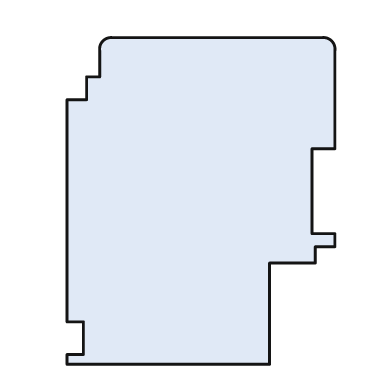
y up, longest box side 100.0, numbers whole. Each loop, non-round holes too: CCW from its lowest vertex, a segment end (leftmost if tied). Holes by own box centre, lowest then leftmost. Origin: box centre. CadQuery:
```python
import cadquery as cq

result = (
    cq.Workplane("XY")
    .moveTo(-41.0, -50.0)
    .lineTo(21.0, -50.0)
    .lineTo(21.0, -19.0)
    .lineTo(35.0, -19.0)
    .lineTo(35.0, -14.0)
    .lineTo(41.0, -14.0)
    .lineTo(41.0, -10.0)
    .lineTo(34.0, -10.0)
    .lineTo(34.0, 16.0)
    .lineTo(41.0, 16.0)
    .lineTo(41.0, 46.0)
    .threePointArc((40.0, 49.0), (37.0, 50.0))
    .lineTo(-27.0, 50.0)
    .threePointArc((-30.0, 49.0), (-31.0, 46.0))
    .lineTo(-31.0, 38.0)
    .lineTo(-35.0, 38.0)
    .lineTo(-35.0, 31.0)
    .lineTo(-41.0, 31.0)
    .lineTo(-41.0, -37.0)
    .lineTo(-36.0, -37.0)
    .lineTo(-36.0, -47.0)
    .lineTo(-41.0, -47.0)
    .close()
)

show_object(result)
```